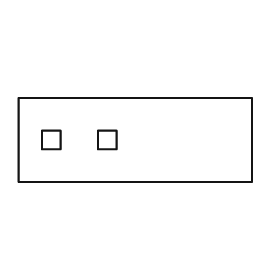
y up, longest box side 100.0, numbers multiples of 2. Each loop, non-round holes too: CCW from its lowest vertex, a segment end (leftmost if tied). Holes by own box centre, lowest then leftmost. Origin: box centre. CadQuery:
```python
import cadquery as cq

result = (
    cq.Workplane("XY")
    .moveTo(-50.0, -18.0)
    .lineTo(50.0, -18.0)
    .lineTo(50.0, 18.0)
    .lineTo(-50.0, 18.0)
    .close()
    .moveTo(-40.0, -4.0)
    .lineTo(-32.0, -4.0)
    .lineTo(-32.0, 4.0)
    .lineTo(-40.0, 4.0)
    .close()
    .moveTo(-16.0, -4.0)
    .lineTo(-8.0, -4.0)
    .lineTo(-8.0, 4.0)
    .lineTo(-16.0, 4.0)
    .close()
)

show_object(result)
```